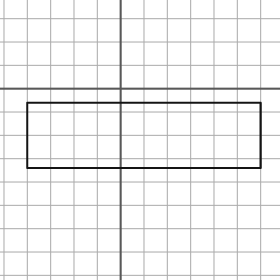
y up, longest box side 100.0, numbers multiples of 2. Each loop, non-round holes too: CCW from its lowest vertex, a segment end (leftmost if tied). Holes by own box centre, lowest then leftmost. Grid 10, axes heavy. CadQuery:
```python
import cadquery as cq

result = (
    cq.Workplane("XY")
    .moveTo(-40.0, -34.0)
    .lineTo(60.0, -34.0)
    .lineTo(60.0, -6.0)
    .lineTo(-40.0, -6.0)
    .close()
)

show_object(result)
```